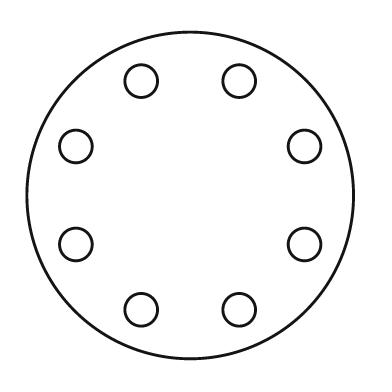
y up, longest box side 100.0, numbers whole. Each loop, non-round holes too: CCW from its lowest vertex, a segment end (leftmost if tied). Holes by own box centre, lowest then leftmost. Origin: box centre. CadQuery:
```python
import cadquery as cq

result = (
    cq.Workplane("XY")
    .moveTo(0.0, 0.0)
    .circle(50.0)
    .moveTo(-15.0, -35.0)
    .circle(5.0)
    .moveTo(15.0, -35.0)
    .circle(5.0)
    .moveTo(-35.0, -15.0)
    .circle(5.0)
    .moveTo(35.0, -15.0)
    .circle(5.0)
    .moveTo(-35.0, 15.0)
    .circle(5.0)
    .moveTo(35.0, 15.0)
    .circle(5.0)
    .moveTo(-15.0, 35.0)
    .circle(5.0)
    .moveTo(15.0, 35.0)
    .circle(5.0)
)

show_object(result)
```